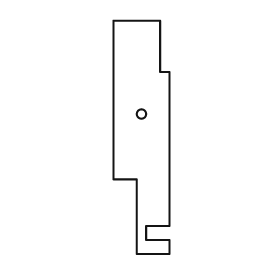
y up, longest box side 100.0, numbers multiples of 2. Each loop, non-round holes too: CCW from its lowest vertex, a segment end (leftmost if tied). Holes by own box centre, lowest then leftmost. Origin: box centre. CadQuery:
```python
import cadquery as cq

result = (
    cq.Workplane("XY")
    .moveTo(-2.0, -50.0)
    .lineTo(12.0, -50.0)
    .lineTo(12.0, -44.0)
    .lineTo(2.0, -44.0)
    .lineTo(2.0, -38.0)
    .lineTo(12.0, -38.0)
    .lineTo(12.0, 28.0)
    .lineTo(8.0, 28.0)
    .lineTo(8.0, 50.0)
    .lineTo(-12.0, 50.0)
    .lineTo(-12.0, -18.0)
    .lineTo(-2.0, -18.0)
    .close()
    .moveTo(0.0, 10.0)
    .circle(2.0)
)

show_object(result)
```